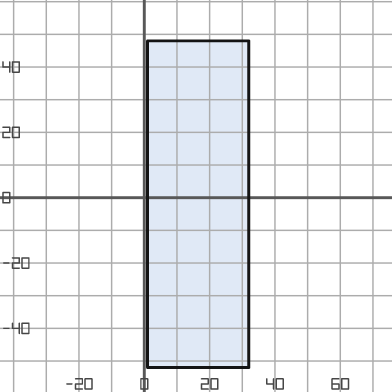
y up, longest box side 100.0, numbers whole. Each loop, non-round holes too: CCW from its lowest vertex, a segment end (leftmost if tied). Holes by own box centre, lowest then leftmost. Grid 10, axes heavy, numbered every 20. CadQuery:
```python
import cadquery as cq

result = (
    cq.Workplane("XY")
    .moveTo(1.0, -52.0)
    .lineTo(32.0, -52.0)
    .lineTo(32.0, 48.0)
    .lineTo(1.0, 48.0)
    .close()
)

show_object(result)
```